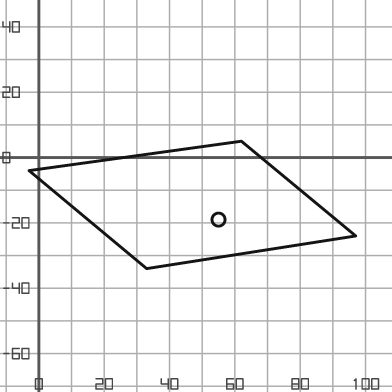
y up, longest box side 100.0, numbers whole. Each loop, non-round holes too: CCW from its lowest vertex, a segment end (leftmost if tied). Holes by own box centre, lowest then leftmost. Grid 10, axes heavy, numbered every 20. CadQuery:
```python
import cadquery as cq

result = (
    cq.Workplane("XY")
    .moveTo(33.0, -34.0)
    .lineTo(97.0, -24.0)
    .lineTo(62.0, 5.0)
    .lineTo(-3.0, -4.0)
    .close()
    .moveTo(55.0, -19.0)
    .circle(2.0)
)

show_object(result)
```